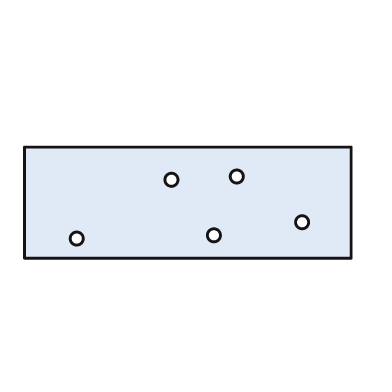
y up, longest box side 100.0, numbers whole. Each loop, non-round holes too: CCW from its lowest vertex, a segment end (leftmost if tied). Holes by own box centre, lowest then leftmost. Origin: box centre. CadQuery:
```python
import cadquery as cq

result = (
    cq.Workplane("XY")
    .moveTo(-50.0, -17.0)
    .lineTo(50.0, -17.0)
    .lineTo(50.0, 17.0)
    .lineTo(-50.0, 17.0)
    .close()
    .moveTo(-34.0, -11.0)
    .circle(2.0)
    .moveTo(8.0, -10.0)
    .circle(2.0)
    .moveTo(35.0, -6.0)
    .circle(2.0)
    .moveTo(-5.0, 7.0)
    .circle(2.0)
    .moveTo(15.0, 8.0)
    .circle(2.0)
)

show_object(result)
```